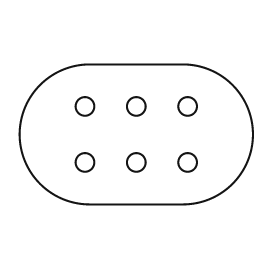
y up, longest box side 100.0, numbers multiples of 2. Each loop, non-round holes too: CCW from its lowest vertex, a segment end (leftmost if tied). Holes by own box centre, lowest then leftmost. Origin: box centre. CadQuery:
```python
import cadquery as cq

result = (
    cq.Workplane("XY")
    .moveTo(-20.0, -30.0)
    .lineTo(20.0, -30.0)
    .threePointArc((50.0, 0.0), (20.0, 30.0))
    .lineTo(-20.0, 30.0)
    .threePointArc((-50.0, 0.0), (-20.0, -30.0))
    .close()
    .moveTo(-22.0, -12.0)
    .circle(4.0)
    .moveTo(0.0, -12.0)
    .circle(4.0)
    .moveTo(22.0, -12.0)
    .circle(4.0)
    .moveTo(-22.0, 12.0)
    .circle(4.0)
    .moveTo(0.0, 12.0)
    .circle(4.0)
    .moveTo(22.0, 12.0)
    .circle(4.0)
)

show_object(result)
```